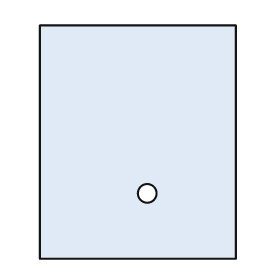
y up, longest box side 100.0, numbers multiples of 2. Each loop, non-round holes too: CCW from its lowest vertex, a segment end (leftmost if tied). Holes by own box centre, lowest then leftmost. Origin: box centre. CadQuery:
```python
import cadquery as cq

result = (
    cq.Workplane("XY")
    .moveTo(-42.0, -50.0)
    .lineTo(42.0, -50.0)
    .lineTo(42.0, 50.0)
    .lineTo(-42.0, 50.0)
    .close()
    .moveTo(4.0, -22.0)
    .circle(4.0)
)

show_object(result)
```